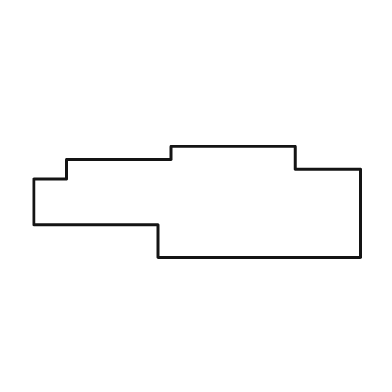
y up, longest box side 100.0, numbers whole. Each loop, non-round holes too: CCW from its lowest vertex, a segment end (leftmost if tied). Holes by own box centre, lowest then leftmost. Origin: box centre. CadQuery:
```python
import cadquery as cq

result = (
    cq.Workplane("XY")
    .moveTo(-12.0, -17.0)
    .lineTo(50.0, -17.0)
    .lineTo(50.0, 10.0)
    .lineTo(30.0, 10.0)
    .lineTo(30.0, 17.0)
    .lineTo(-8.0, 17.0)
    .lineTo(-8.0, 13.0)
    .lineTo(-40.0, 13.0)
    .lineTo(-40.0, 7.0)
    .lineTo(-50.0, 7.0)
    .lineTo(-50.0, -7.0)
    .lineTo(-12.0, -7.0)
    .close()
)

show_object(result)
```